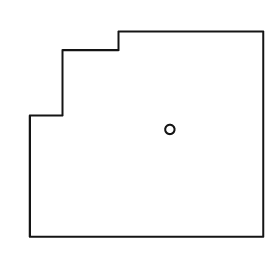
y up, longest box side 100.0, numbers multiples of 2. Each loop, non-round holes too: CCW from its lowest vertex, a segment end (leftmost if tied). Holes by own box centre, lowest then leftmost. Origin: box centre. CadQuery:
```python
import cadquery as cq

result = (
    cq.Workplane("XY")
    .moveTo(-50.0, -44.0)
    .lineTo(50.0, -44.0)
    .lineTo(50.0, 44.0)
    .lineTo(-12.0, 44.0)
    .lineTo(-12.0, 36.0)
    .lineTo(-36.0, 36.0)
    .lineTo(-36.0, 8.0)
    .lineTo(-50.0, 8.0)
    .close()
    .moveTo(10.0, 2.0)
    .circle(2.0)
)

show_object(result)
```